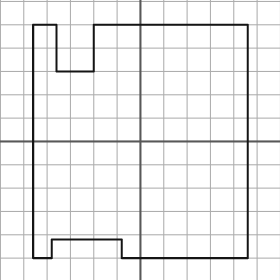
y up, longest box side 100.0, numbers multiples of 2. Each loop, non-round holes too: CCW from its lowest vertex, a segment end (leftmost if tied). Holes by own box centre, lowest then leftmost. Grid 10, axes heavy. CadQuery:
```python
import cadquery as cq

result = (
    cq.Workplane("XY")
    .moveTo(-46.0, -50.0)
    .lineTo(-38.0, -50.0)
    .lineTo(-38.0, -42.0)
    .lineTo(-8.0, -42.0)
    .lineTo(-8.0, -50.0)
    .lineTo(46.0, -50.0)
    .lineTo(46.0, 50.0)
    .lineTo(-20.0, 50.0)
    .lineTo(-20.0, 30.0)
    .lineTo(-36.0, 30.0)
    .lineTo(-36.0, 50.0)
    .lineTo(-46.0, 50.0)
    .close()
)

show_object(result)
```